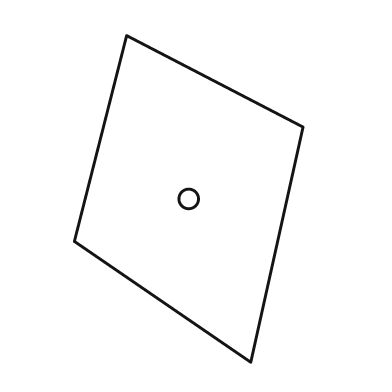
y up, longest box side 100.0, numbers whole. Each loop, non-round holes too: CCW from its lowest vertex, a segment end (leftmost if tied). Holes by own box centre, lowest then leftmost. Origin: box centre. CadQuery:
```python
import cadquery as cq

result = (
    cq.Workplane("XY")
    .moveTo(19.0, -50.0)
    .lineTo(35.0, 22.0)
    .lineTo(-19.0, 50.0)
    .lineTo(-35.0, -13.0)
    .close()
    .moveTo(0.0, 0.0)
    .circle(3.0)
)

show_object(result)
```